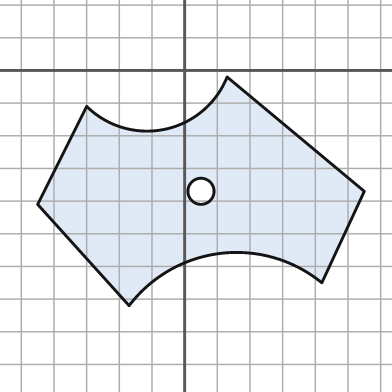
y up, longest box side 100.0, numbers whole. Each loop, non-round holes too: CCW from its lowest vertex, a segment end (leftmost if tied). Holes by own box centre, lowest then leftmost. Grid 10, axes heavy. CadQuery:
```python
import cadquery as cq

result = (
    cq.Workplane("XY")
    .moveTo(-17.0, -72.0)
    .threePointArc((11.0, -56.0), (42.0, -65.0))
    .lineTo(55.0, -37.0)
    .lineTo(13.0, -2.0)
    .threePointArc((-6.0, -18.0), (-30.0, -11.0))
    .lineTo(-45.0, -41.0)
    .close()
    .moveTo(5.0, -37.0)
    .circle(4.0)
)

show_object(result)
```